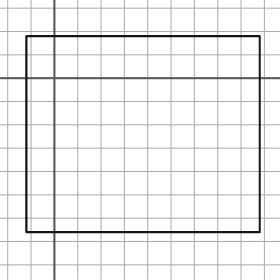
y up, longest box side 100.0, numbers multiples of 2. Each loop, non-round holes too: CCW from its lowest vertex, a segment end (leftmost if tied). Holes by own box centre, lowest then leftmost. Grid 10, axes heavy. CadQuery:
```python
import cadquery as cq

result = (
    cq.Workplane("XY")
    .moveTo(-12.0, -66.0)
    .lineTo(88.0, -66.0)
    .lineTo(88.0, 18.0)
    .lineTo(-12.0, 18.0)
    .close()
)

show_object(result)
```